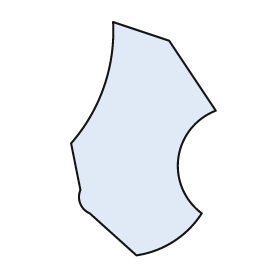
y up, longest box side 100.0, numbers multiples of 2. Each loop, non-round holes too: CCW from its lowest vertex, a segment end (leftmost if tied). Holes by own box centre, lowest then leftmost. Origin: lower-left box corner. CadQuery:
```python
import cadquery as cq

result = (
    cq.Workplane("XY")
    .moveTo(28.0, 0.0)
    .threePointArc((44.0, 6.0), (56.0, 18.0))
    .threePointArc((46.0, 42.0), (62.0, 62.0))
    .lineTo(42.0, 92.0)
    .lineTo(18.0, 100.0)
    .threePointArc((14.0, 72.0), (0.0, 48.0))
    .lineTo(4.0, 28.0)
    .threePointArc((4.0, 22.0), (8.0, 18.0))
    .close()
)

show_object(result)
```